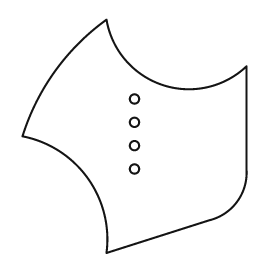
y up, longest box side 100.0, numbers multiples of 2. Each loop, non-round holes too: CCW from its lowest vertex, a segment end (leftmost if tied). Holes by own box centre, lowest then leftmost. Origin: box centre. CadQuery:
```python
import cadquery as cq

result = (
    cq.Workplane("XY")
    .moveTo(-12.0, -50.0)
    .lineTo(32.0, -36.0)
    .threePointArc((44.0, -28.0), (48.0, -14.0))
    .lineTo(48.0, 30.0)
    .threePointArc((12.0, 22.0), (-12.0, 50.0))
    .threePointArc((-34.0, 28.0), (-48.0, 0.0))
    .threePointArc((-20.0, -18.0), (-12.0, -50.0))
    .close()
    .moveTo(0.0, -14.0)
    .circle(2.0)
    .moveTo(0.0, -4.0)
    .circle(2.0)
    .moveTo(0.0, 6.0)
    .circle(2.0)
    .moveTo(0.0, 16.0)
    .circle(2.0)
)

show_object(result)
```